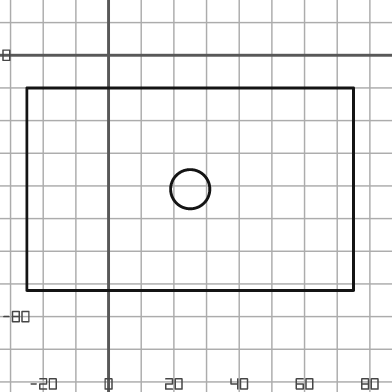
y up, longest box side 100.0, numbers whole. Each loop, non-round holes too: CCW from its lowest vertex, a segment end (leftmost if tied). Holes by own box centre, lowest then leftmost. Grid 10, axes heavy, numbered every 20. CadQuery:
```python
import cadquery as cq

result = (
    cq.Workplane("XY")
    .moveTo(-25.0, -72.0)
    .lineTo(75.0, -72.0)
    .lineTo(75.0, -10.0)
    .lineTo(-25.0, -10.0)
    .close()
    .moveTo(25.0, -41.0)
    .circle(6.0)
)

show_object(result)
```